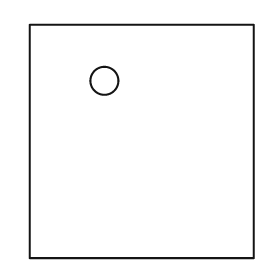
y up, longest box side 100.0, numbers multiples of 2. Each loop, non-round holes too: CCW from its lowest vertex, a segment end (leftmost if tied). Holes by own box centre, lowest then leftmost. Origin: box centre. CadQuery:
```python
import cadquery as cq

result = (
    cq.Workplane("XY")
    .moveTo(-48.0, -50.0)
    .lineTo(48.0, -50.0)
    .lineTo(48.0, 50.0)
    .lineTo(-48.0, 50.0)
    .close()
    .moveTo(-16.0, 26.0)
    .circle(6.0)
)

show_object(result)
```